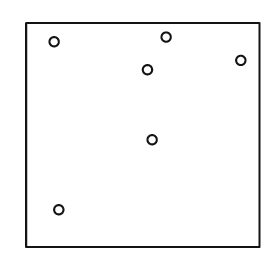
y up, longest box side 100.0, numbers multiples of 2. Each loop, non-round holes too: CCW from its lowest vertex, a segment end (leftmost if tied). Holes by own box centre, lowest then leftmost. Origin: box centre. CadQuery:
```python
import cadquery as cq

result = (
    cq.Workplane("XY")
    .moveTo(-50.0, -48.0)
    .lineTo(50.0, -48.0)
    .lineTo(50.0, 48.0)
    .lineTo(-50.0, 48.0)
    .close()
    .moveTo(-36.0, -32.0)
    .circle(2.0)
    .moveTo(4.0, -2.0)
    .circle(2.0)
    .moveTo(2.0, 28.0)
    .circle(2.0)
    .moveTo(42.0, 32.0)
    .circle(2.0)
    .moveTo(-38.0, 40.0)
    .circle(2.0)
    .moveTo(10.0, 42.0)
    .circle(2.0)
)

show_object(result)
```